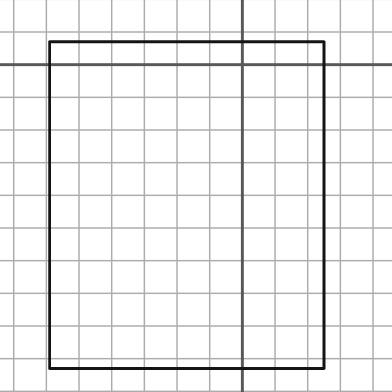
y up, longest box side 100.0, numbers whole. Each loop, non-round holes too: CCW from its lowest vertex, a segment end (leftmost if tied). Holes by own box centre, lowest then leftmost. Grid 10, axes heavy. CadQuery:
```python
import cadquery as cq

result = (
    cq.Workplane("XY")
    .moveTo(-59.0, -93.0)
    .lineTo(25.0, -93.0)
    .lineTo(25.0, 7.0)
    .lineTo(-59.0, 7.0)
    .close()
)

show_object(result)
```